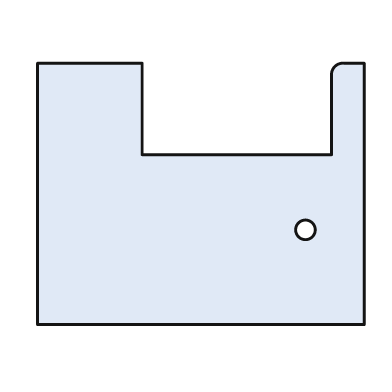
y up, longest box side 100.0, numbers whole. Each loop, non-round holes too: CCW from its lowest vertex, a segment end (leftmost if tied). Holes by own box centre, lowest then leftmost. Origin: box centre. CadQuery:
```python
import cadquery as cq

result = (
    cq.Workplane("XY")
    .moveTo(-50.0, -40.0)
    .lineTo(50.0, -40.0)
    .lineTo(50.0, 40.0)
    .lineTo(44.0, 40.0)
    .threePointArc((41.0, 39.0), (40.0, 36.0))
    .lineTo(40.0, 12.0)
    .lineTo(-18.0, 12.0)
    .lineTo(-18.0, 40.0)
    .lineTo(-50.0, 40.0)
    .close()
    .moveTo(32.0, -11.0)
    .circle(3.0)
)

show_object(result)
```